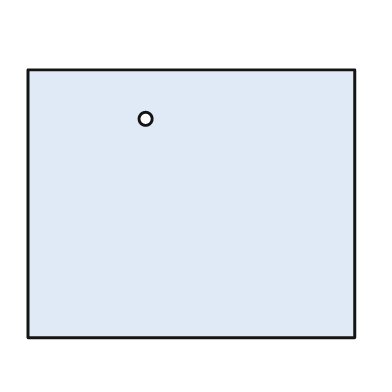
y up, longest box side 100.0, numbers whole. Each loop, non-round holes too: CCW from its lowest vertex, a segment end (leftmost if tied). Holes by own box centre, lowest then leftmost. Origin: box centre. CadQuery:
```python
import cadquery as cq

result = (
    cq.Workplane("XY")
    .moveTo(-50.0, -41.0)
    .lineTo(50.0, -41.0)
    .lineTo(50.0, 41.0)
    .lineTo(-50.0, 41.0)
    .close()
    .moveTo(-14.0, 26.0)
    .circle(2.0)
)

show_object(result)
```